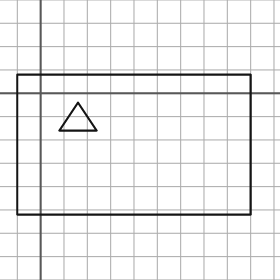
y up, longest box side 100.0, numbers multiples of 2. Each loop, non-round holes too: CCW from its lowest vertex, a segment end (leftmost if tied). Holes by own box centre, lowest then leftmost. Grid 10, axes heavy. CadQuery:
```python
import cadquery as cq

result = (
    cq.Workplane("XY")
    .moveTo(-10.0, -52.0)
    .lineTo(90.0, -52.0)
    .lineTo(90.0, 8.0)
    .lineTo(-10.0, 8.0)
    .close()
    .moveTo(8.0, -16.0)
    .lineTo(24.0, -16.0)
    .lineTo(16.0, -4.0)
    .close()
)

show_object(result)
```